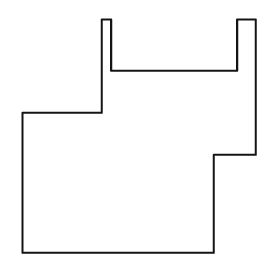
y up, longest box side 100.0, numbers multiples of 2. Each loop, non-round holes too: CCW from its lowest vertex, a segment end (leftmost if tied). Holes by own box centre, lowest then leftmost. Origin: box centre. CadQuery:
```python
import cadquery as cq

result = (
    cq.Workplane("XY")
    .moveTo(-50.0, -50.0)
    .lineTo(32.0, -50.0)
    .lineTo(32.0, -8.0)
    .lineTo(50.0, -8.0)
    .lineTo(50.0, 50.0)
    .lineTo(42.0, 50.0)
    .lineTo(42.0, 28.0)
    .lineTo(-12.0, 28.0)
    .lineTo(-12.0, 50.0)
    .lineTo(-16.0, 50.0)
    .lineTo(-16.0, 10.0)
    .lineTo(-50.0, 10.0)
    .close()
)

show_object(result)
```